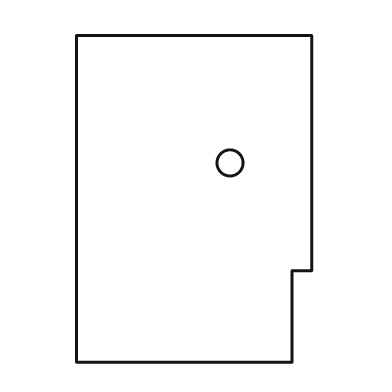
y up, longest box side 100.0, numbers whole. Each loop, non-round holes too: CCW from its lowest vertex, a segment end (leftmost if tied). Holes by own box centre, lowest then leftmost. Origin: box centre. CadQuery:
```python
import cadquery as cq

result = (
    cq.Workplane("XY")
    .moveTo(-36.0, -50.0)
    .lineTo(30.0, -50.0)
    .lineTo(30.0, -22.0)
    .lineTo(36.0, -22.0)
    .lineTo(36.0, 50.0)
    .lineTo(-36.0, 50.0)
    .close()
    .moveTo(11.0, 11.0)
    .circle(4.0)
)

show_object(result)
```